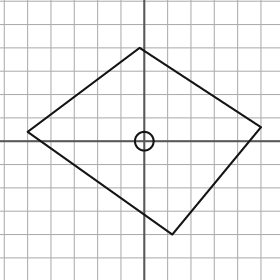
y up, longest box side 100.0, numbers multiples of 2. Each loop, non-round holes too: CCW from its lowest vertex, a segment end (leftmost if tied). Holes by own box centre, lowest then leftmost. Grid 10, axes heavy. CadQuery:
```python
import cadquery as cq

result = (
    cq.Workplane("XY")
    .moveTo(12.0, -40.0)
    .lineTo(50.0, 6.0)
    .lineTo(-2.0, 40.0)
    .lineTo(-50.0, 4.0)
    .close()
    .moveTo(0.0, 0.0)
    .circle(4.0)
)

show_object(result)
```